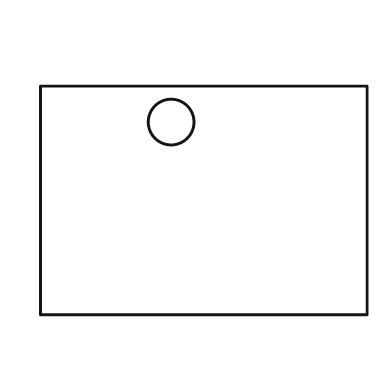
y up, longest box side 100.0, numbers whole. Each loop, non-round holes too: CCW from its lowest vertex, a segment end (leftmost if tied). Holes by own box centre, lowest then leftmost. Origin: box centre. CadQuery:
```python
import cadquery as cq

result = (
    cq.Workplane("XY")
    .moveTo(-50.0, -35.0)
    .lineTo(50.0, -35.0)
    .lineTo(50.0, 35.0)
    .lineTo(-50.0, 35.0)
    .close()
    .moveTo(-10.0, 24.0)
    .circle(7.0)
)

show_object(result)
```